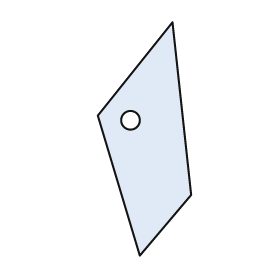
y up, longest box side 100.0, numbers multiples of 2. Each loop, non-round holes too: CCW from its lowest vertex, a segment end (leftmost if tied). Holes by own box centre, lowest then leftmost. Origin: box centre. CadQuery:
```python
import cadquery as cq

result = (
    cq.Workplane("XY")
    .moveTo(-2.0, -50.0)
    .lineTo(20.0, -24.0)
    .lineTo(12.0, 50.0)
    .lineTo(-20.0, 10.0)
    .close()
    .moveTo(-6.0, 8.0)
    .circle(4.0)
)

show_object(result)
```